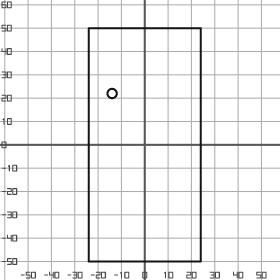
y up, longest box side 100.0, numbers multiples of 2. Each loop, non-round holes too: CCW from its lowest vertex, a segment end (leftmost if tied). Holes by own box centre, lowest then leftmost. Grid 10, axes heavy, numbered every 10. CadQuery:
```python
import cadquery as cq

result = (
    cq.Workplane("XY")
    .moveTo(-24.0, -50.0)
    .lineTo(24.0, -50.0)
    .lineTo(24.0, 50.0)
    .lineTo(-24.0, 50.0)
    .close()
    .moveTo(-14.0, 22.0)
    .circle(2.0)
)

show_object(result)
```